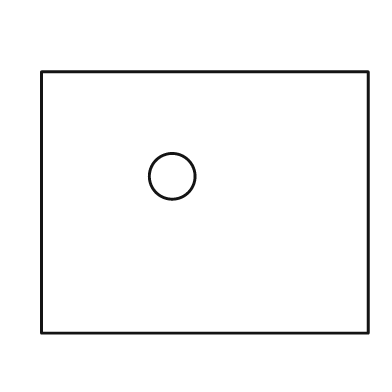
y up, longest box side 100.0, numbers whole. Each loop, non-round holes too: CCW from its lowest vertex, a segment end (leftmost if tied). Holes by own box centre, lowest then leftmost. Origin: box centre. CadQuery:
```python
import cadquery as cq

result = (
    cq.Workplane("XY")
    .moveTo(-50.0, -40.0)
    .lineTo(50.0, -40.0)
    .lineTo(50.0, 40.0)
    .lineTo(-50.0, 40.0)
    .close()
    .moveTo(-10.0, 8.0)
    .circle(7.0)
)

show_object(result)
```